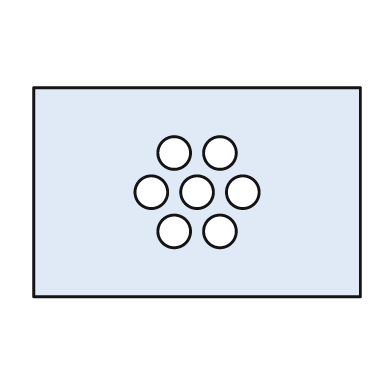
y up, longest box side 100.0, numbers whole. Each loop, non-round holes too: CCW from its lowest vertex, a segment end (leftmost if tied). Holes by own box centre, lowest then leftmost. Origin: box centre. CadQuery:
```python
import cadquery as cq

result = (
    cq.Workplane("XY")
    .moveTo(-50.0, -32.0)
    .lineTo(50.0, -32.0)
    .lineTo(50.0, 32.0)
    .lineTo(-50.0, 32.0)
    .close()
    .moveTo(-7.0, -12.0)
    .circle(5.0)
    .moveTo(7.0, -12.0)
    .circle(5.0)
    .moveTo(-14.0, 0.0)
    .circle(5.0)
    .moveTo(0.0, 0.0)
    .circle(5.0)
    .moveTo(14.0, 0.0)
    .circle(5.0)
    .moveTo(-7.0, 12.0)
    .circle(5.0)
    .moveTo(7.0, 12.0)
    .circle(5.0)
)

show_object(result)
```